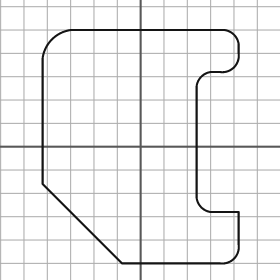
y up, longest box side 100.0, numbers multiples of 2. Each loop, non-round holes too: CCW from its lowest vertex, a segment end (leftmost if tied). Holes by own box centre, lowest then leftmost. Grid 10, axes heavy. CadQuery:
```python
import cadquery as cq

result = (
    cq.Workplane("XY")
    .moveTo(-8.0, -50.0)
    .lineTo(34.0, -50.0)
    .threePointArc((40.0, -48.0), (42.0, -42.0))
    .lineTo(42.0, -28.0)
    .lineTo(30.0, -28.0)
    .threePointArc((26.0, -26.0), (24.0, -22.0))
    .lineTo(24.0, 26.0)
    .threePointArc((26.0, 30.0), (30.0, 32.0))
    .lineTo(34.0, 32.0)
    .threePointArc((40.0, 34.0), (42.0, 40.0))
    .lineTo(42.0, 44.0)
    .threePointArc((40.0, 48.0), (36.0, 50.0))
    .lineTo(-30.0, 50.0)
    .threePointArc((-38.0, 46.0), (-42.0, 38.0))
    .lineTo(-42.0, -16.0)
    .close()
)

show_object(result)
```